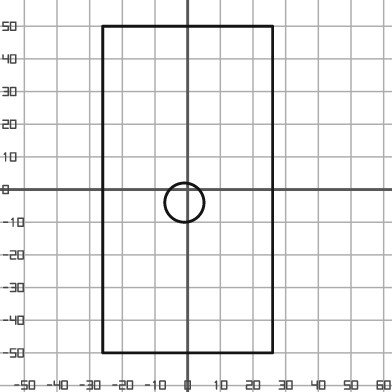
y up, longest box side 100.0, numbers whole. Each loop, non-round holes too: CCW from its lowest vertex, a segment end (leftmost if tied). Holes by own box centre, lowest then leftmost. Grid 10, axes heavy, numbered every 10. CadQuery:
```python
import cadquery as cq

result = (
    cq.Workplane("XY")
    .moveTo(-26.0, -50.0)
    .lineTo(26.0, -50.0)
    .lineTo(26.0, 50.0)
    .lineTo(-26.0, 50.0)
    .close()
    .moveTo(-1.0, -4.0)
    .circle(6.0)
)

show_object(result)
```